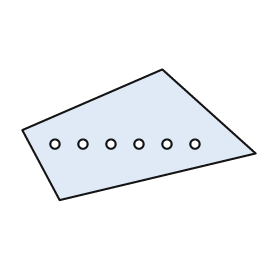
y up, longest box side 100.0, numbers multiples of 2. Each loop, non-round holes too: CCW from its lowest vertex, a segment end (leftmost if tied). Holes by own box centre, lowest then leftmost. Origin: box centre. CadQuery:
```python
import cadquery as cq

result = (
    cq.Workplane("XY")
    .moveTo(-34.0, -28.0)
    .lineTo(50.0, -8.0)
    .lineTo(10.0, 28.0)
    .lineTo(-50.0, 2.0)
    .close()
    .moveTo(-36.0, -4.0)
    .circle(2.0)
    .moveTo(-24.0, -4.0)
    .circle(2.0)
    .moveTo(-12.0, -4.0)
    .circle(2.0)
    .moveTo(0.0, -4.0)
    .circle(2.0)
    .moveTo(12.0, -4.0)
    .circle(2.0)
    .moveTo(24.0, -4.0)
    .circle(2.0)
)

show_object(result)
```